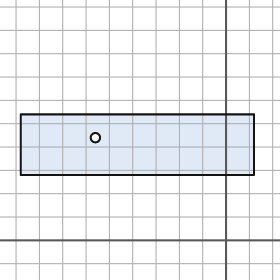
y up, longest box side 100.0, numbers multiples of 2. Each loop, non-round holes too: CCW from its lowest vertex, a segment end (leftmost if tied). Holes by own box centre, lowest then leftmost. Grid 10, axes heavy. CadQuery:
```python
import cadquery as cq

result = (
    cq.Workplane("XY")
    .moveTo(-88.0, 28.0)
    .lineTo(12.0, 28.0)
    .lineTo(12.0, 54.0)
    .lineTo(-88.0, 54.0)
    .close()
    .moveTo(-56.0, 44.0)
    .circle(2.0)
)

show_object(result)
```